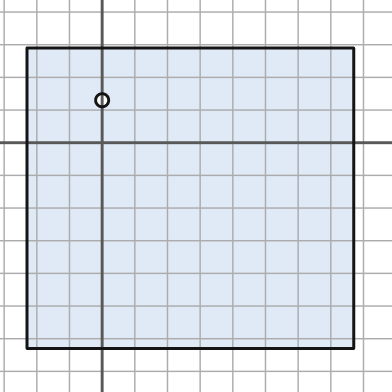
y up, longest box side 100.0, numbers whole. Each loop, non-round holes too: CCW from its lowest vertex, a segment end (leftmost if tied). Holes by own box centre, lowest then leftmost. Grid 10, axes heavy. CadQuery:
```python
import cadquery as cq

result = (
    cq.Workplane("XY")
    .moveTo(-23.0, -63.0)
    .lineTo(77.0, -63.0)
    .lineTo(77.0, 29.0)
    .lineTo(-23.0, 29.0)
    .close()
    .moveTo(0.0, 13.0)
    .circle(2.0)
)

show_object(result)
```